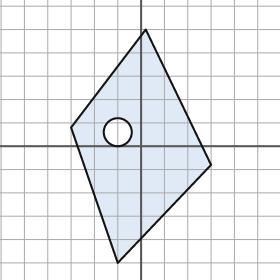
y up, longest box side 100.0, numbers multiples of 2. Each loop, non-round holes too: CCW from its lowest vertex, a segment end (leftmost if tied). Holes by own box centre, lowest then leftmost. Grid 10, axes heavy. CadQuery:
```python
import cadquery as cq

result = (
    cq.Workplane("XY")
    .moveTo(-10.0, -50.0)
    .lineTo(30.0, -8.0)
    .lineTo(2.0, 50.0)
    .lineTo(-30.0, 8.0)
    .close()
    .moveTo(-10.0, 6.0)
    .circle(6.0)
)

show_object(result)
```